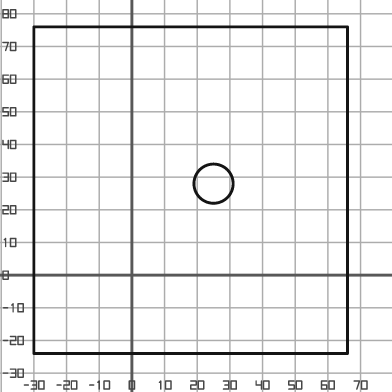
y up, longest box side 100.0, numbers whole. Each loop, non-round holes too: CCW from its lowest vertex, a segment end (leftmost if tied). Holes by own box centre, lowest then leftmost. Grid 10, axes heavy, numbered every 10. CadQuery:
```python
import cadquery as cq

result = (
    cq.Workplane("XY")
    .moveTo(-30.0, -24.0)
    .lineTo(66.0, -24.0)
    .lineTo(66.0, 76.0)
    .lineTo(-30.0, 76.0)
    .close()
    .moveTo(25.0, 28.0)
    .circle(6.0)
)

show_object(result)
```